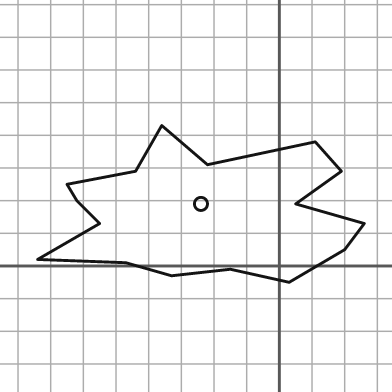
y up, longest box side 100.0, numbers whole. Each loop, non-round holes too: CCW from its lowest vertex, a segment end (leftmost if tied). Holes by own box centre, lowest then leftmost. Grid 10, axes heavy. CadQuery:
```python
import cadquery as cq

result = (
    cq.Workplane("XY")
    .moveTo(3.0, -5.0)
    .lineTo(20.0, 5.0)
    .lineTo(26.0, 13.0)
    .lineTo(5.0, 19.0)
    .lineTo(19.0, 29.0)
    .lineTo(11.0, 38.0)
    .lineTo(-22.0, 31.0)
    .lineTo(-36.0, 43.0)
    .lineTo(-44.0, 29.0)
    .lineTo(-65.0, 25.0)
    .lineTo(-62.0, 20.0)
    .lineTo(-55.0, 13.0)
    .lineTo(-74.0, 2.0)
    .lineTo(-47.0, 1.0)
    .lineTo(-33.0, -3.0)
    .lineTo(-15.0, -1.0)
    .close()
    .moveTo(-24.0, 19.0)
    .circle(2.0)
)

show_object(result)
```